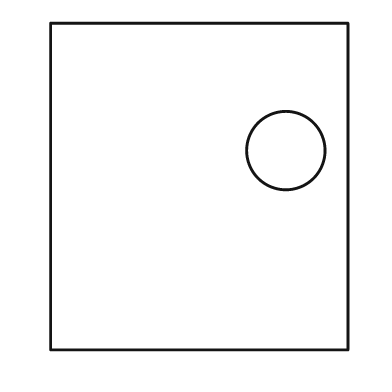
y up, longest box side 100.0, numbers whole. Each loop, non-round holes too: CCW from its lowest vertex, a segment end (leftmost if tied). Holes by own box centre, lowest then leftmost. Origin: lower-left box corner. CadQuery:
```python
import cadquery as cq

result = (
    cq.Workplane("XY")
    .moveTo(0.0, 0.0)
    .lineTo(91.0, 0.0)
    .lineTo(91.0, 100.0)
    .lineTo(0.0, 100.0)
    .close()
    .moveTo(72.0, 61.0)
    .circle(12.0)
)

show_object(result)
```